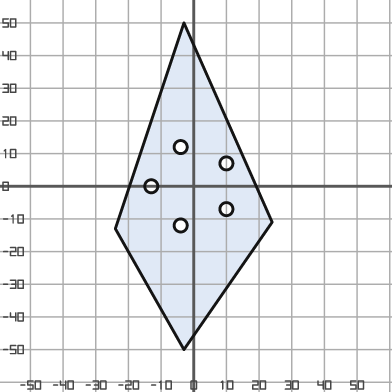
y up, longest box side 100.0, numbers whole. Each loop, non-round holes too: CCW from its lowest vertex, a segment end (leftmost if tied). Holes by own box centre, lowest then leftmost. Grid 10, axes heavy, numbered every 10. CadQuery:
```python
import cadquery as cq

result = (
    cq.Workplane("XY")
    .moveTo(-3.0, -50.0)
    .lineTo(24.0, -11.0)
    .lineTo(-3.0, 50.0)
    .lineTo(-24.0, -13.0)
    .close()
    .moveTo(-4.0, -12.0)
    .circle(2.0)
    .moveTo(10.0, -7.0)
    .circle(2.0)
    .moveTo(-13.0, 0.0)
    .circle(2.0)
    .moveTo(10.0, 7.0)
    .circle(2.0)
    .moveTo(-4.0, 12.0)
    .circle(2.0)
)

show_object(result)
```